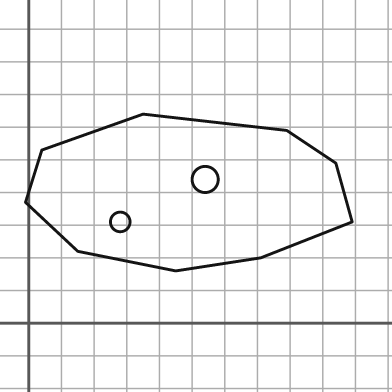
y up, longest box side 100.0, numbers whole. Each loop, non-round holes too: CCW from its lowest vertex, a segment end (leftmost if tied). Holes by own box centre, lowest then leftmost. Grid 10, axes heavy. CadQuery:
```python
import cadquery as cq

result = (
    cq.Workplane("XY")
    .moveTo(45.0, 16.0)
    .lineTo(71.0, 20.0)
    .lineTo(99.0, 31.0)
    .lineTo(94.0, 49.0)
    .lineTo(79.0, 59.0)
    .lineTo(35.0, 64.0)
    .lineTo(4.0, 53.0)
    .lineTo(-1.0, 37.0)
    .lineTo(15.0, 22.0)
    .close()
    .moveTo(28.0, 31.0)
    .circle(3.0)
    .moveTo(54.0, 44.0)
    .circle(4.0)
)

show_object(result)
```